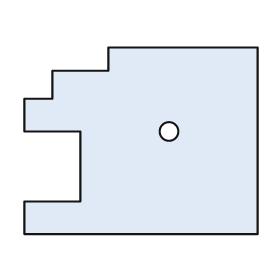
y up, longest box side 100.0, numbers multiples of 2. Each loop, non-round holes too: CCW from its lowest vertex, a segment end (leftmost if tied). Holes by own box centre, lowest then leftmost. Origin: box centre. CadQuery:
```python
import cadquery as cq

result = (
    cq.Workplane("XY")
    .moveTo(-50.0, -40.0)
    .lineTo(50.0, -40.0)
    .lineTo(50.0, 40.0)
    .lineTo(-14.0, 40.0)
    .lineTo(-14.0, 30.0)
    .lineTo(-38.0, 30.0)
    .lineTo(-38.0, 18.0)
    .lineTo(-50.0, 18.0)
    .lineTo(-50.0, 4.0)
    .lineTo(-26.0, 4.0)
    .lineTo(-26.0, -26.0)
    .lineTo(-50.0, -26.0)
    .close()
    .moveTo(12.0, 4.0)
    .circle(4.0)
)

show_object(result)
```